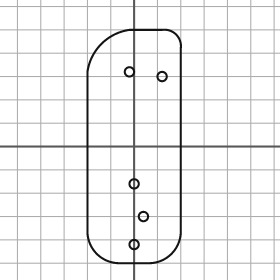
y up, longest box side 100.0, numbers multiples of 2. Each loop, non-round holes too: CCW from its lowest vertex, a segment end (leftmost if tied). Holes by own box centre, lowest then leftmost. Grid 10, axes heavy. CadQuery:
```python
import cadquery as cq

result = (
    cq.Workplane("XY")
    .moveTo(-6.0, -50.0)
    .lineTo(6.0, -50.0)
    .threePointArc((16.0, -46.0), (20.0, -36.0))
    .lineTo(20.0, 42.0)
    .threePointArc((18.0, 48.0), (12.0, 50.0))
    .lineTo(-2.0, 50.0)
    .threePointArc((-14.0, 44.0), (-20.0, 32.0))
    .lineTo(-20.0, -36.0)
    .threePointArc((-16.0, -46.0), (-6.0, -50.0))
    .close()
    .moveTo(0.0, -42.0)
    .circle(2.0)
    .moveTo(4.0, -30.0)
    .circle(2.0)
    .moveTo(0.0, -16.0)
    .circle(2.0)
    .moveTo(12.0, 30.0)
    .circle(2.0)
    .moveTo(-2.0, 32.0)
    .circle(2.0)
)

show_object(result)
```